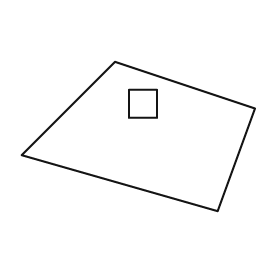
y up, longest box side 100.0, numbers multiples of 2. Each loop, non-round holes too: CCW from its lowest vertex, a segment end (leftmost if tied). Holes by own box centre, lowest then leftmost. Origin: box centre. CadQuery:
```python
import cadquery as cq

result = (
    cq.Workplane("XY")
    .moveTo(34.0, -32.0)
    .lineTo(50.0, 12.0)
    .lineTo(-10.0, 32.0)
    .lineTo(-50.0, -8.0)
    .close()
    .moveTo(-4.0, 8.0)
    .lineTo(8.0, 8.0)
    .lineTo(8.0, 20.0)
    .lineTo(-4.0, 20.0)
    .close()
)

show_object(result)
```